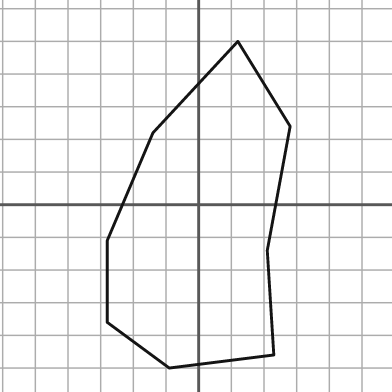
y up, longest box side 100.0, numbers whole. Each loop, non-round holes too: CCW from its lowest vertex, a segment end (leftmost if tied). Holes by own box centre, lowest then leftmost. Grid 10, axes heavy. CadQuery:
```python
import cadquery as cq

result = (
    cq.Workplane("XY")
    .moveTo(-9.0, -50.0)
    .lineTo(23.0, -46.0)
    .lineTo(21.0, -14.0)
    .lineTo(28.0, 24.0)
    .lineTo(12.0, 50.0)
    .lineTo(-14.0, 22.0)
    .lineTo(-28.0, -11.0)
    .lineTo(-28.0, -36.0)
    .close()
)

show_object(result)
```